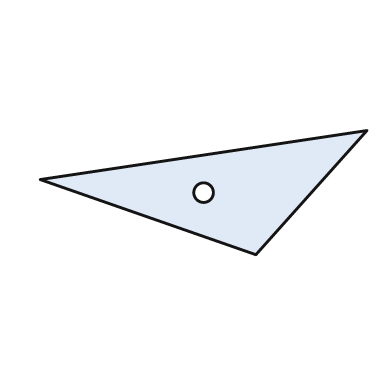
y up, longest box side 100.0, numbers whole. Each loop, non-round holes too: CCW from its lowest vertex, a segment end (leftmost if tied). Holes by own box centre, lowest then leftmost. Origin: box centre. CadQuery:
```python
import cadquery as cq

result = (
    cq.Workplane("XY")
    .moveTo(16.0, -19.0)
    .lineTo(50.0, 19.0)
    .lineTo(-50.0, 4.0)
    .close()
    .moveTo(0.0, 0.0)
    .circle(3.0)
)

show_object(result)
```